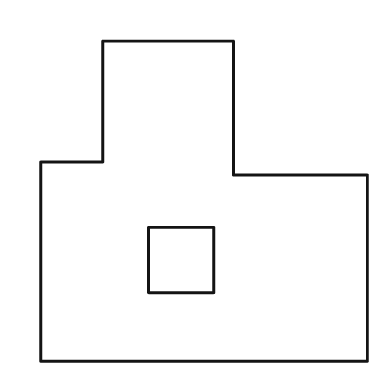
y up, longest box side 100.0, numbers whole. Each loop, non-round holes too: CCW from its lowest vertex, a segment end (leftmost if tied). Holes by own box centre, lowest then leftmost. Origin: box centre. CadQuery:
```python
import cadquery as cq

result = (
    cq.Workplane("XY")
    .moveTo(-50.0, -49.0)
    .lineTo(50.0, -49.0)
    .lineTo(50.0, 8.0)
    .lineTo(9.0, 8.0)
    .lineTo(9.0, 49.0)
    .lineTo(-31.0, 49.0)
    .lineTo(-31.0, 12.0)
    .lineTo(-50.0, 12.0)
    .close()
    .moveTo(-17.0, -28.0)
    .lineTo(3.0, -28.0)
    .lineTo(3.0, -8.0)
    .lineTo(-17.0, -8.0)
    .close()
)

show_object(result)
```